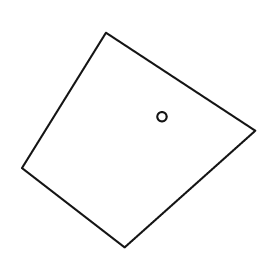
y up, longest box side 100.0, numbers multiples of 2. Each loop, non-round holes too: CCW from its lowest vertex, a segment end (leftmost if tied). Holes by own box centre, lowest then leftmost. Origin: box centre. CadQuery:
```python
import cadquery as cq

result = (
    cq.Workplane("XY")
    .moveTo(-6.0, -46.0)
    .lineTo(50.0, 4.0)
    .lineTo(-14.0, 46.0)
    .lineTo(-50.0, -12.0)
    .close()
    .moveTo(10.0, 10.0)
    .circle(2.0)
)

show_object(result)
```